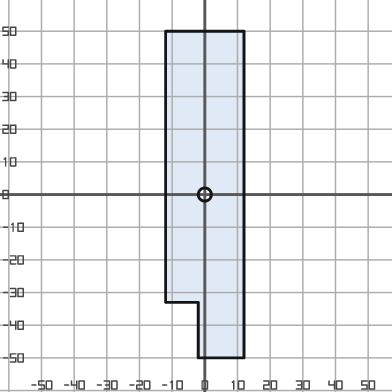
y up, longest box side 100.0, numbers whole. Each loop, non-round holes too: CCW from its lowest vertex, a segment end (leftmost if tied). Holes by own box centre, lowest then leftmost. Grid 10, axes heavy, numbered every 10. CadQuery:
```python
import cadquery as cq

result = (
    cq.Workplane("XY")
    .moveTo(-2.0, -50.0)
    .lineTo(12.0, -50.0)
    .lineTo(12.0, 50.0)
    .lineTo(-12.0, 50.0)
    .lineTo(-12.0, -33.0)
    .lineTo(-2.0, -33.0)
    .close()
    .moveTo(0.0, 0.0)
    .circle(2.0)
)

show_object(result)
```